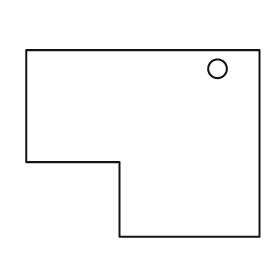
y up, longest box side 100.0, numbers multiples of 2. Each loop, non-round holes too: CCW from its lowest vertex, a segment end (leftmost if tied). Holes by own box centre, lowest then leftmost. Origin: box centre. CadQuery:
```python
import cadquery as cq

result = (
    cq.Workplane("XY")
    .moveTo(-10.0, -40.0)
    .lineTo(50.0, -40.0)
    .lineTo(50.0, 40.0)
    .lineTo(-50.0, 40.0)
    .lineTo(-50.0, -8.0)
    .lineTo(-10.0, -8.0)
    .close()
    .moveTo(32.0, 32.0)
    .circle(4.0)
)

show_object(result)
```